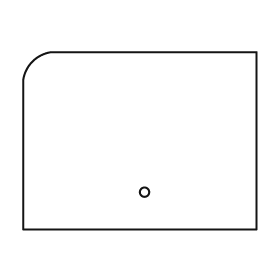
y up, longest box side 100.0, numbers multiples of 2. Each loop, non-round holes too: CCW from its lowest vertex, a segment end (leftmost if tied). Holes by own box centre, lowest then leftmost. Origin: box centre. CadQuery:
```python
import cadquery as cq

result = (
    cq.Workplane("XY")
    .moveTo(-50.0, -38.0)
    .lineTo(50.0, -38.0)
    .lineTo(50.0, 38.0)
    .lineTo(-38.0, 38.0)
    .threePointArc((-46.0, 34.0), (-50.0, 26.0))
    .close()
    .moveTo(2.0, -22.0)
    .circle(2.0)
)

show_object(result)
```